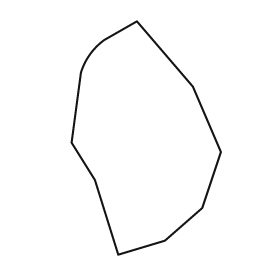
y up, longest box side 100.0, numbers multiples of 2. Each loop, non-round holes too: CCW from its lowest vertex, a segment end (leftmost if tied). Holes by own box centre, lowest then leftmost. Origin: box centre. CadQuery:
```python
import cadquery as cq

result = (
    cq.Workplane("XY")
    .moveTo(-12.0, -50.0)
    .lineTo(8.0, -44.0)
    .lineTo(24.0, -30.0)
    .lineTo(32.0, -6.0)
    .lineTo(20.0, 22.0)
    .lineTo(-4.0, 50.0)
    .lineTo(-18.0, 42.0)
    .threePointArc((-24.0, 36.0), (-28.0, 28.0))
    .lineTo(-32.0, -2.0)
    .lineTo(-22.0, -18.0)
    .close()
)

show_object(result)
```